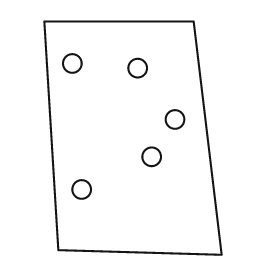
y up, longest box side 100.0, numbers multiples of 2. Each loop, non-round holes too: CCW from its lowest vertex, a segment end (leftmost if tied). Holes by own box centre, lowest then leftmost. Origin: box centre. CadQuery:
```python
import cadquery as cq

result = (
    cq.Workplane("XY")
    .moveTo(38.0, -50.0)
    .lineTo(26.0, 50.0)
    .lineTo(-38.0, 50.0)
    .lineTo(-32.0, -48.0)
    .close()
    .moveTo(-22.0, -22.0)
    .circle(4.0)
    .moveTo(8.0, -8.0)
    .circle(4.0)
    .moveTo(18.0, 8.0)
    .circle(4.0)
    .moveTo(2.0, 30.0)
    .circle(4.0)
    .moveTo(-26.0, 32.0)
    .circle(4.0)
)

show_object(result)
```